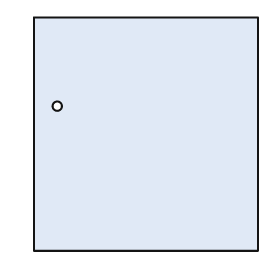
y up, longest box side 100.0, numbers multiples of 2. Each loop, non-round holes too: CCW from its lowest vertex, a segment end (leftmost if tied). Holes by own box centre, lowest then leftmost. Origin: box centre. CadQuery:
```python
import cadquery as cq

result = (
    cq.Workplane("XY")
    .moveTo(-48.0, -50.0)
    .lineTo(48.0, -50.0)
    .lineTo(48.0, 50.0)
    .lineTo(-48.0, 50.0)
    .close()
    .moveTo(-38.0, 12.0)
    .circle(2.0)
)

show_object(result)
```